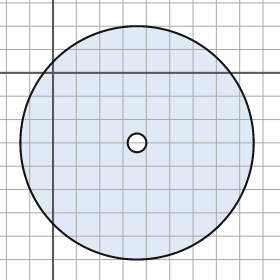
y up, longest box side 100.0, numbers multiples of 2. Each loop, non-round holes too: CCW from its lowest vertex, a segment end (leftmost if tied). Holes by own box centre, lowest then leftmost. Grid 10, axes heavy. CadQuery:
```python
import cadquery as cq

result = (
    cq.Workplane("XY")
    .moveTo(36.0, -30.0)
    .circle(50.0)
    .moveTo(36.0, -30.0)
    .circle(4.0)
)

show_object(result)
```